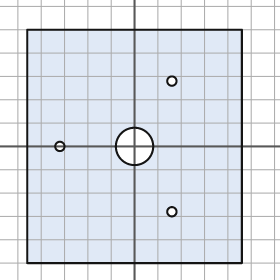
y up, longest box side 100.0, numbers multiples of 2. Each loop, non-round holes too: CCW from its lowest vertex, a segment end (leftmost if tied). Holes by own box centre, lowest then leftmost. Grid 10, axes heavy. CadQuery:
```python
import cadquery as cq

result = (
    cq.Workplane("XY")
    .moveTo(-46.0, -50.0)
    .lineTo(46.0, -50.0)
    .lineTo(46.0, 50.0)
    .lineTo(-46.0, 50.0)
    .close()
    .moveTo(16.0, -28.0)
    .circle(2.0)
    .moveTo(-32.0, 0.0)
    .circle(2.0)
    .moveTo(0.0, 0.0)
    .circle(8.0)
    .moveTo(16.0, 28.0)
    .circle(2.0)
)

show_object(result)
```